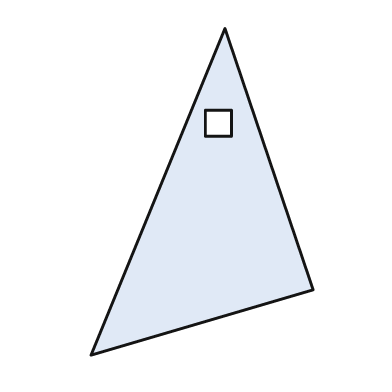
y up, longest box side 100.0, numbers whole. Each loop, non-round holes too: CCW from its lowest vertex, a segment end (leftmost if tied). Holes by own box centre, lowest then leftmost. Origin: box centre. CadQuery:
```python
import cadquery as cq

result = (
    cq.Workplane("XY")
    .moveTo(-34.0, -50.0)
    .lineTo(34.0, -30.0)
    .lineTo(7.0, 50.0)
    .close()
    .moveTo(1.0, 17.0)
    .lineTo(9.0, 17.0)
    .lineTo(9.0, 25.0)
    .lineTo(1.0, 25.0)
    .close()
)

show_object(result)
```